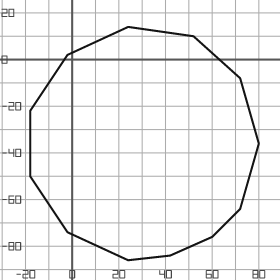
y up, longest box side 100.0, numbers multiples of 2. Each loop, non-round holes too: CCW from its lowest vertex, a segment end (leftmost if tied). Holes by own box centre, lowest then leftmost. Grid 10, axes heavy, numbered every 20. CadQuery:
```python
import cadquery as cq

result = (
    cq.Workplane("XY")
    .moveTo(24.0, -86.0)
    .lineTo(42.0, -84.0)
    .lineTo(60.0, -76.0)
    .lineTo(72.0, -64.0)
    .lineTo(80.0, -36.0)
    .lineTo(72.0, -8.0)
    .lineTo(52.0, 10.0)
    .lineTo(24.0, 14.0)
    .lineTo(-2.0, 2.0)
    .lineTo(-18.0, -22.0)
    .lineTo(-18.0, -50.0)
    .lineTo(-2.0, -74.0)
    .close()
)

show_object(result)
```